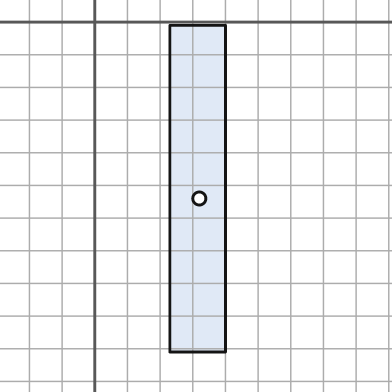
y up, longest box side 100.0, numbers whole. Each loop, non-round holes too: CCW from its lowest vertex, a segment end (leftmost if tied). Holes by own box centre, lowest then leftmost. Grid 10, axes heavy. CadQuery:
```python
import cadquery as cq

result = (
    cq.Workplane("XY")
    .moveTo(23.0, -101.0)
    .lineTo(40.0, -101.0)
    .lineTo(40.0, -1.0)
    .lineTo(23.0, -1.0)
    .close()
    .moveTo(32.0, -54.0)
    .circle(2.0)
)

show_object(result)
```